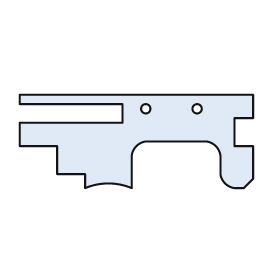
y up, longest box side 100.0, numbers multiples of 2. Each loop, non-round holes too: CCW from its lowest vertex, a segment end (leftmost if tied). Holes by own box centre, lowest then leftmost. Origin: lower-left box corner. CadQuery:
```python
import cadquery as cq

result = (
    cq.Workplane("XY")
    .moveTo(28.0, 0.0)
    .threePointArc((38.0, 2.0), (48.0, 0.0))
    .lineTo(48.0, 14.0)
    .threePointArc((50.0, 18.0), (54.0, 20.0))
    .lineTo(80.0, 20.0)
    .threePointArc((84.0, 18.0), (86.0, 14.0))
    .lineTo(86.0, 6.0)
    .threePointArc((88.0, 2.0), (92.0, 0.0))
    .lineTo(96.0, 0.0)
    .lineTo(100.0, 4.0)
    .lineTo(100.0, 18.0)
    .lineTo(92.0, 18.0)
    .lineTo(92.0, 30.0)
    .lineTo(100.0, 30.0)
    .lineTo(100.0, 40.0)
    .lineTo(0.0, 40.0)
    .lineTo(0.0, 36.0)
    .lineTo(44.0, 36.0)
    .lineTo(44.0, 28.0)
    .lineTo(0.0, 28.0)
    .lineTo(0.0, 18.0)
    .lineTo(16.0, 18.0)
    .lineTo(16.0, 6.0)
    .lineTo(28.0, 6.0)
    .close()
    .moveTo(54.0, 34.0)
    .circle(2.0)
    .moveTo(76.0, 34.0)
    .circle(2.0)
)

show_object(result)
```